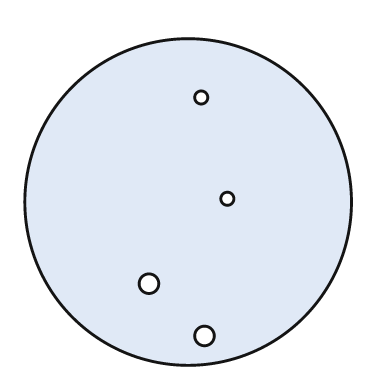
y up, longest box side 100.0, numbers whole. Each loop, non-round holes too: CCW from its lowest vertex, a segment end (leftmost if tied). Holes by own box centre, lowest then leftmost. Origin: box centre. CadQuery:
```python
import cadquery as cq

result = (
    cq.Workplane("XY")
    .moveTo(0.0, 0.0)
    .circle(50.0)
    .moveTo(5.0, -41.0)
    .circle(3.0)
    .moveTo(-12.0, -25.0)
    .circle(3.0)
    .moveTo(12.0, 1.0)
    .circle(2.0)
    .moveTo(4.0, 32.0)
    .circle(2.0)
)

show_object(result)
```